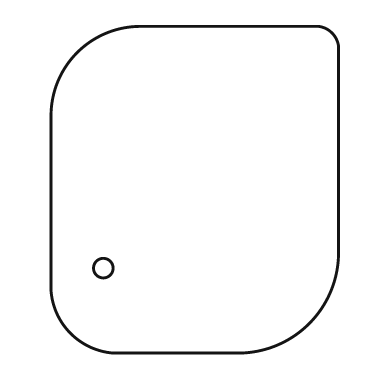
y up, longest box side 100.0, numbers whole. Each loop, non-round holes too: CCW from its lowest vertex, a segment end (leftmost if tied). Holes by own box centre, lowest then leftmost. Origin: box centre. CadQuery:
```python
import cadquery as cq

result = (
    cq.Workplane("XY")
    .moveTo(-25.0, -50.0)
    .lineTo(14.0, -50.0)
    .threePointArc((35.0, -41.0), (44.0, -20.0))
    .lineTo(44.0, 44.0)
    .threePointArc((42.0, 48.0), (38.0, 50.0))
    .lineTo(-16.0, 50.0)
    .threePointArc((-36.0, 42.0), (-44.0, 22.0))
    .lineTo(-44.0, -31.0)
    .threePointArc((-38.0, -44.0), (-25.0, -50.0))
    .close()
    .moveTo(-28.0, -24.0)
    .circle(3.0)
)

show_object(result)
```